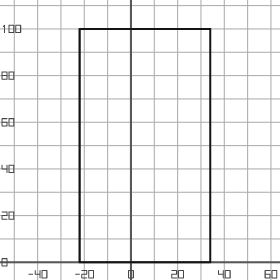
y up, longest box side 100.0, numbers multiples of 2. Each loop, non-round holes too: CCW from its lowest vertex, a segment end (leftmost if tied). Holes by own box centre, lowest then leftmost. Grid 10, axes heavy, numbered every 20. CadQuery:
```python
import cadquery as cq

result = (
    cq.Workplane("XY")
    .moveTo(-22.0, 0.0)
    .lineTo(34.0, 0.0)
    .lineTo(34.0, 100.0)
    .lineTo(-22.0, 100.0)
    .close()
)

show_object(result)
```